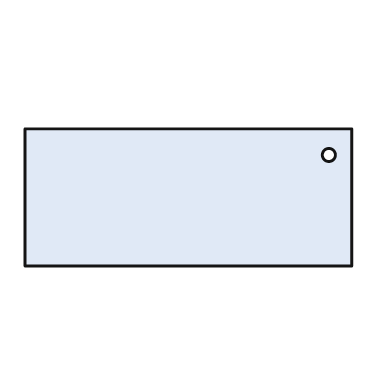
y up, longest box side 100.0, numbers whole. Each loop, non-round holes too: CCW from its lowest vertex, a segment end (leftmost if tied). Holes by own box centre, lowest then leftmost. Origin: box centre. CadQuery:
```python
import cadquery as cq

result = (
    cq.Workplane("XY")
    .moveTo(-50.0, -21.0)
    .lineTo(50.0, -21.0)
    .lineTo(50.0, 21.0)
    .lineTo(-50.0, 21.0)
    .close()
    .moveTo(43.0, 13.0)
    .circle(2.0)
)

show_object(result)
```